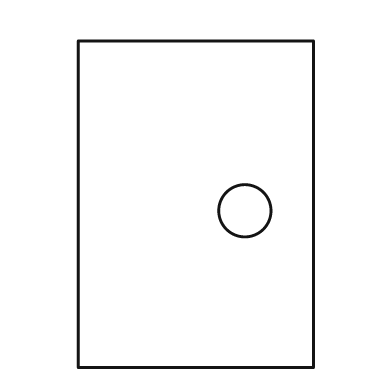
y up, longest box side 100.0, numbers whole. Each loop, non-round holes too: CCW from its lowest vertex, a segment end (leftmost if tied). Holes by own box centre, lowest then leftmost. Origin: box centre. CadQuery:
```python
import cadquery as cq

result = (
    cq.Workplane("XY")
    .moveTo(-36.0, -50.0)
    .lineTo(36.0, -50.0)
    .lineTo(36.0, 50.0)
    .lineTo(-36.0, 50.0)
    .close()
    .moveTo(15.0, -2.0)
    .circle(8.0)
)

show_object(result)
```